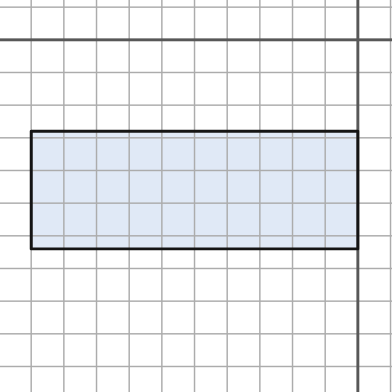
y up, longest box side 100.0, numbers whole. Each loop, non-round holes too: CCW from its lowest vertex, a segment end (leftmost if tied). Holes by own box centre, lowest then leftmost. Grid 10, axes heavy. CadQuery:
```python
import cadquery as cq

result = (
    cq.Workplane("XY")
    .moveTo(-100.0, -64.0)
    .lineTo(0.0, -64.0)
    .lineTo(0.0, -28.0)
    .lineTo(-100.0, -28.0)
    .close()
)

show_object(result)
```